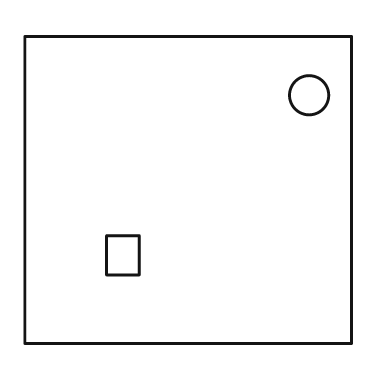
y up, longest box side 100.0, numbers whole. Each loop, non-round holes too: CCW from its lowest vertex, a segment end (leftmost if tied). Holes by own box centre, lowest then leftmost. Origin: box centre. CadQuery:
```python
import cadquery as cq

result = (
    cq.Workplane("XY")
    .moveTo(-50.0, -47.0)
    .lineTo(50.0, -47.0)
    .lineTo(50.0, 47.0)
    .lineTo(-50.0, 47.0)
    .close()
    .moveTo(-25.0, -26.0)
    .lineTo(-15.0, -26.0)
    .lineTo(-15.0, -14.0)
    .lineTo(-25.0, -14.0)
    .close()
    .moveTo(37.0, 29.0)
    .circle(6.0)
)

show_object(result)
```